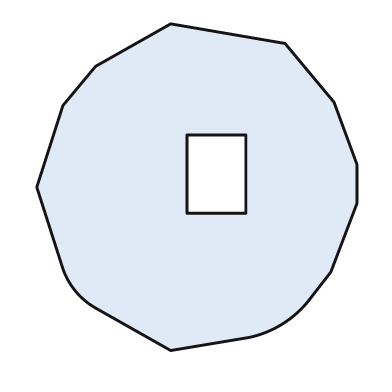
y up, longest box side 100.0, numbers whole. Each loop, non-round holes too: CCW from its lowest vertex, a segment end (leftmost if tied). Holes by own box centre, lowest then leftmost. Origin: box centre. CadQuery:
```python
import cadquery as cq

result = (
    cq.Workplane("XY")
    .moveTo(-8.0, -50.0)
    .lineTo(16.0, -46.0)
    .threePointArc((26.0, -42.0), (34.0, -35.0))
    .lineTo(41.0, -26.0)
    .lineTo(49.0, -5.0)
    .lineTo(49.0, 7.0)
    .lineTo(42.0, 26.0)
    .lineTo(27.0, 44.0)
    .lineTo(-8.0, 50.0)
    .lineTo(-31.0, 37.0)
    .lineTo(-41.0, 25.0)
    .lineTo(-49.0, 0.0)
    .lineTo(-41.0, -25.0)
    .threePointArc((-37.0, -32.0), (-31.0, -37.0))
    .close()
    .moveTo(-3.0, -8.0)
    .lineTo(15.0, -8.0)
    .lineTo(15.0, 16.0)
    .lineTo(-3.0, 16.0)
    .close()
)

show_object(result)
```